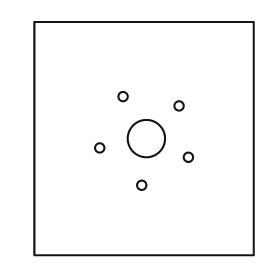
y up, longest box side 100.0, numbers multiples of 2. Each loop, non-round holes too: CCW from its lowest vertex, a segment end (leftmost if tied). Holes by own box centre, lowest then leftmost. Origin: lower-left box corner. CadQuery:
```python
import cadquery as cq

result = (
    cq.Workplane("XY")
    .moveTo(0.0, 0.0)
    .lineTo(94.0, 0.0)
    .lineTo(94.0, 100.0)
    .lineTo(0.0, 100.0)
    .close()
    .moveTo(46.0, 30.0)
    .circle(2.0)
    .moveTo(66.0, 42.0)
    .circle(2.0)
    .moveTo(28.0, 46.0)
    .circle(2.0)
    .moveTo(48.0, 50.0)
    .circle(8.0)
    .moveTo(62.0, 64.0)
    .circle(2.0)
    .moveTo(38.0, 68.0)
    .circle(2.0)
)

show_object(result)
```